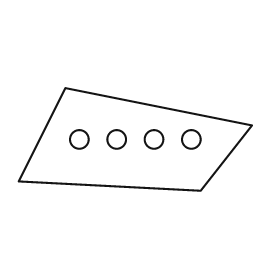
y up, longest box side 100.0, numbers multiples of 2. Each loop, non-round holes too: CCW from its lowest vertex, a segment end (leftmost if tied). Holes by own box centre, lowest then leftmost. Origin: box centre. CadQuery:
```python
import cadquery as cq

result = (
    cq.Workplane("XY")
    .moveTo(28.0, -22.0)
    .lineTo(50.0, 6.0)
    .lineTo(-30.0, 22.0)
    .lineTo(-50.0, -18.0)
    .close()
    .moveTo(-24.0, 0.0)
    .circle(4.0)
    .moveTo(-8.0, 0.0)
    .circle(4.0)
    .moveTo(8.0, 0.0)
    .circle(4.0)
    .moveTo(24.0, 0.0)
    .circle(4.0)
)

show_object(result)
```